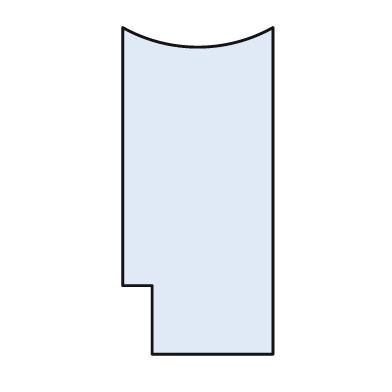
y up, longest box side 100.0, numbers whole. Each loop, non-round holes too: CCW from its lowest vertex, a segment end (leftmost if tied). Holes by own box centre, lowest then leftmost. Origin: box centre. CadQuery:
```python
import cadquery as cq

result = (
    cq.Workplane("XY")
    .moveTo(-14.0, -50.0)
    .lineTo(23.0, -50.0)
    .lineTo(23.0, 50.0)
    .threePointArc((0.0, 44.0), (-23.0, 50.0))
    .lineTo(-23.0, -29.0)
    .lineTo(-14.0, -29.0)
    .close()
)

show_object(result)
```